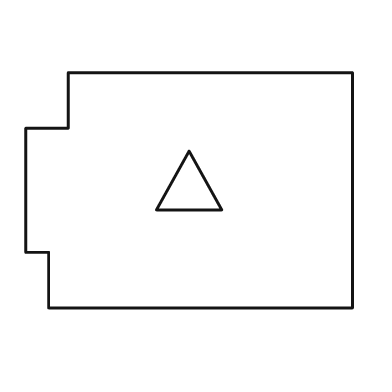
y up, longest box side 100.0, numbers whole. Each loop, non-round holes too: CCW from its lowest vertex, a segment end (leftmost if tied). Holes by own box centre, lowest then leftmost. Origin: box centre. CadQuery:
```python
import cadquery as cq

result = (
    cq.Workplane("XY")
    .moveTo(-43.0, -36.0)
    .lineTo(50.0, -36.0)
    .lineTo(50.0, 36.0)
    .lineTo(-37.0, 36.0)
    .lineTo(-37.0, 19.0)
    .lineTo(-50.0, 19.0)
    .lineTo(-50.0, -19.0)
    .lineTo(-43.0, -19.0)
    .close()
    .moveTo(-10.0, -6.0)
    .lineTo(10.0, -6.0)
    .lineTo(0.0, 12.0)
    .close()
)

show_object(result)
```